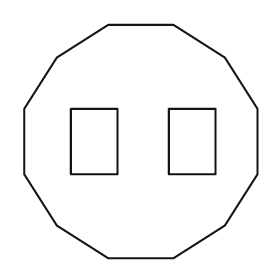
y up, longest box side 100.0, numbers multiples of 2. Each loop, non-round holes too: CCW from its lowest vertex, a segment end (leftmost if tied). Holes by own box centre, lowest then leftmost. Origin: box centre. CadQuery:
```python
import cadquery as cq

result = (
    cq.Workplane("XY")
    .moveTo(-14.0, -50.0)
    .lineTo(14.0, -50.0)
    .lineTo(36.0, -36.0)
    .lineTo(50.0, -14.0)
    .lineTo(50.0, 14.0)
    .lineTo(36.0, 36.0)
    .lineTo(14.0, 50.0)
    .lineTo(-14.0, 50.0)
    .lineTo(-36.0, 36.0)
    .lineTo(-50.0, 14.0)
    .lineTo(-50.0, -14.0)
    .lineTo(-36.0, -36.0)
    .close()
    .moveTo(-30.0, -14.0)
    .lineTo(-10.0, -14.0)
    .lineTo(-10.0, 14.0)
    .lineTo(-30.0, 14.0)
    .close()
    .moveTo(12.0, -14.0)
    .lineTo(32.0, -14.0)
    .lineTo(32.0, 14.0)
    .lineTo(12.0, 14.0)
    .close()
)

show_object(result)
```